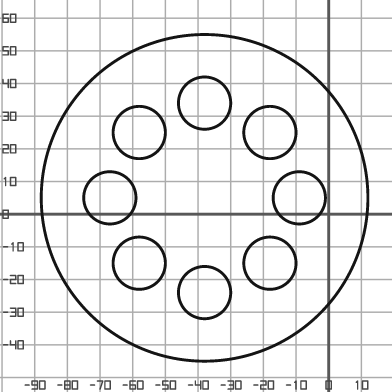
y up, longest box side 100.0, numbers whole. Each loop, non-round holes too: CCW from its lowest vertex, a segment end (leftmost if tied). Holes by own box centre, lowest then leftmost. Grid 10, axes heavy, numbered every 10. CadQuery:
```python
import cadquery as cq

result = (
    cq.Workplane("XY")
    .moveTo(-38.0, 5.0)
    .circle(50.0)
    .moveTo(-38.0, -24.0)
    .circle(8.0)
    .moveTo(-58.0, -15.0)
    .circle(8.0)
    .moveTo(-18.0, -15.0)
    .circle(8.0)
    .moveTo(-67.0, 5.0)
    .circle(8.0)
    .moveTo(-9.0, 5.0)
    .circle(8.0)
    .moveTo(-58.0, 25.0)
    .circle(8.0)
    .moveTo(-18.0, 25.0)
    .circle(8.0)
    .moveTo(-38.0, 34.0)
    .circle(8.0)
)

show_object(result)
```